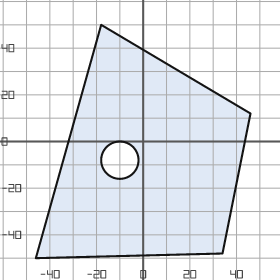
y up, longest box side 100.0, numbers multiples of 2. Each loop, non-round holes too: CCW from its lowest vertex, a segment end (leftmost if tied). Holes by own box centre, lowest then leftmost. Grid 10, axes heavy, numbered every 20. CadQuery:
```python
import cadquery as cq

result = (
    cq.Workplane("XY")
    .moveTo(-46.0, -50.0)
    .lineTo(34.0, -48.0)
    .lineTo(46.0, 12.0)
    .lineTo(-18.0, 50.0)
    .close()
    .moveTo(-10.0, -8.0)
    .circle(8.0)
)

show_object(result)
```